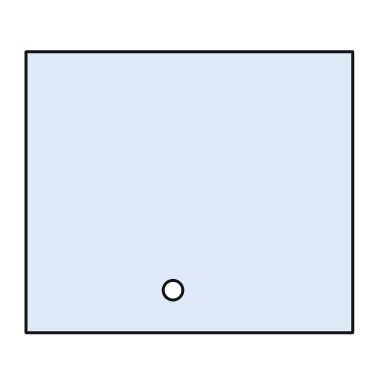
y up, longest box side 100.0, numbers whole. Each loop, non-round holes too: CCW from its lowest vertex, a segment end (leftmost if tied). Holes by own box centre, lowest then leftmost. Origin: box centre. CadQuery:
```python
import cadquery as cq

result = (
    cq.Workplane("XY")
    .moveTo(-50.0, -43.0)
    .lineTo(50.0, -43.0)
    .lineTo(50.0, 43.0)
    .lineTo(-50.0, 43.0)
    .close()
    .moveTo(-5.0, -30.0)
    .circle(3.0)
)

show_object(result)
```